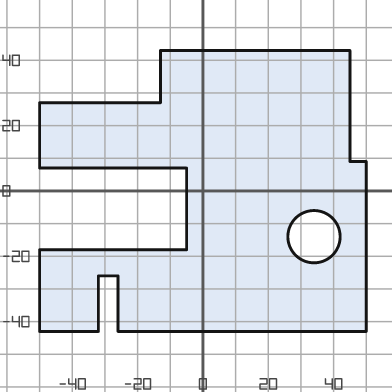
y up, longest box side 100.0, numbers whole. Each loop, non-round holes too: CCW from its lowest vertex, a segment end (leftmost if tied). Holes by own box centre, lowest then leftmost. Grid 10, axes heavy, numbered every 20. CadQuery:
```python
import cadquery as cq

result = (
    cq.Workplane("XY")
    .moveTo(-50.0, -43.0)
    .lineTo(-32.0, -43.0)
    .lineTo(-32.0, -26.0)
    .lineTo(-26.0, -26.0)
    .lineTo(-26.0, -43.0)
    .lineTo(50.0, -43.0)
    .lineTo(50.0, 9.0)
    .lineTo(45.0, 9.0)
    .lineTo(45.0, 43.0)
    .lineTo(-13.0, 43.0)
    .lineTo(-13.0, 27.0)
    .lineTo(-50.0, 27.0)
    .lineTo(-50.0, 7.0)
    .lineTo(-5.0, 7.0)
    .lineTo(-5.0, -18.0)
    .lineTo(-50.0, -18.0)
    .close()
    .moveTo(34.0, -14.0)
    .circle(8.0)
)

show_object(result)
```